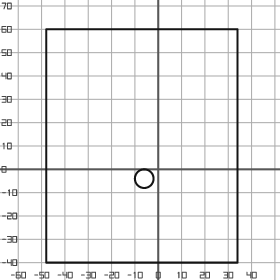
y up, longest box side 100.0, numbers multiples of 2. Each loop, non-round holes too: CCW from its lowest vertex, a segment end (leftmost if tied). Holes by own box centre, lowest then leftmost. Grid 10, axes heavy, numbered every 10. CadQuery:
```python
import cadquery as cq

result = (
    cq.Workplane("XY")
    .moveTo(-48.0, -40.0)
    .lineTo(34.0, -40.0)
    .lineTo(34.0, 60.0)
    .lineTo(-48.0, 60.0)
    .close()
    .moveTo(-6.0, -4.0)
    .circle(4.0)
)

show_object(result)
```